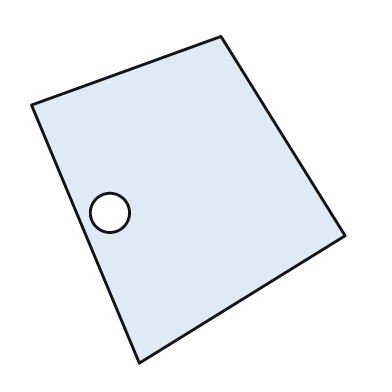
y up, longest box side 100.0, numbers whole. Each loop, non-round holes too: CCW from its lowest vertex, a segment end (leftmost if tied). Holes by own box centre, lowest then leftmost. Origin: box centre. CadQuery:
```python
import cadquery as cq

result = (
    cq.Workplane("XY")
    .moveTo(-15.0, -50.0)
    .lineTo(48.0, -11.0)
    .lineTo(10.0, 50.0)
    .lineTo(-48.0, 29.0)
    .close()
    .moveTo(-24.0, -4.0)
    .circle(6.0)
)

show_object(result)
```